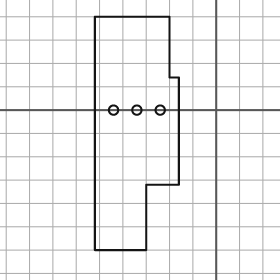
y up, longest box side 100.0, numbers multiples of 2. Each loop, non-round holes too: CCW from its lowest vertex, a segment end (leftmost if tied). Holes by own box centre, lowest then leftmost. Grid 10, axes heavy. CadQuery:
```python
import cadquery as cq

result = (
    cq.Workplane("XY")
    .moveTo(-52.0, -60.0)
    .lineTo(-30.0, -60.0)
    .lineTo(-30.0, -32.0)
    .lineTo(-16.0, -32.0)
    .lineTo(-16.0, 14.0)
    .lineTo(-20.0, 14.0)
    .lineTo(-20.0, 40.0)
    .lineTo(-52.0, 40.0)
    .close()
    .moveTo(-44.0, 0.0)
    .circle(2.0)
    .moveTo(-34.0, 0.0)
    .circle(2.0)
    .moveTo(-24.0, 0.0)
    .circle(2.0)
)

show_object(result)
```